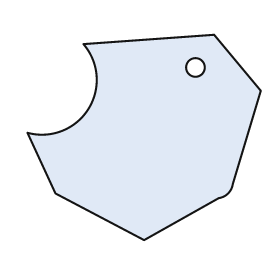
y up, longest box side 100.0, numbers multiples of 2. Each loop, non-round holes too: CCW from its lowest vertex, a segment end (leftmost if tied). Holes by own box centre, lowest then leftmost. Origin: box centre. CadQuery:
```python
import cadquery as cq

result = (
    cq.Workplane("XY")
    .moveTo(0.0, -44.0)
    .lineTo(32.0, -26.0)
    .threePointArc((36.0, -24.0), (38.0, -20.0))
    .lineTo(50.0, 20.0)
    .lineTo(30.0, 44.0)
    .lineTo(-26.0, 40.0)
    .threePointArc((-24.0, 12.0), (-50.0, 2.0))
    .lineTo(-38.0, -24.0)
    .close()
    .moveTo(22.0, 30.0)
    .circle(4.0)
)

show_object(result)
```